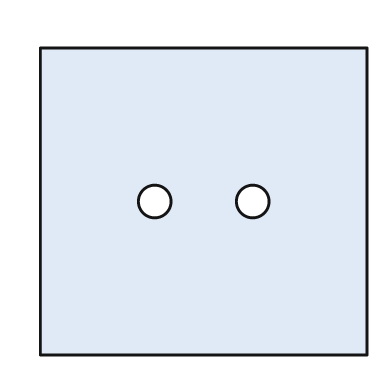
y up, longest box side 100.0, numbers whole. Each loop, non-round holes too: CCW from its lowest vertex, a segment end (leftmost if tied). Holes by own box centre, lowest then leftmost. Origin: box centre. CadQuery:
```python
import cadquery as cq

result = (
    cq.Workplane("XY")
    .moveTo(-50.0, -47.0)
    .lineTo(50.0, -47.0)
    .lineTo(50.0, 47.0)
    .lineTo(-50.0, 47.0)
    .close()
    .moveTo(-15.0, 0.0)
    .circle(5.0)
    .moveTo(15.0, 0.0)
    .circle(5.0)
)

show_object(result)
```